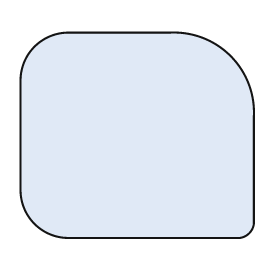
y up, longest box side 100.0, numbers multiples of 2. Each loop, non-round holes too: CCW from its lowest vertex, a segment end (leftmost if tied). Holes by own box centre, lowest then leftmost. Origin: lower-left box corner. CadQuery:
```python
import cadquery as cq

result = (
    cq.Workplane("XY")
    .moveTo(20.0, 0.0)
    .lineTo(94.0, 0.0)
    .threePointArc((98.0, 2.0), (100.0, 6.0))
    .lineTo(100.0, 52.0)
    .threePointArc((90.0, 78.0), (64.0, 88.0))
    .lineTo(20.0, 88.0)
    .threePointArc((6.0, 82.0), (0.0, 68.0))
    .lineTo(0.0, 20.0)
    .threePointArc((6.0, 6.0), (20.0, 0.0))
    .close()
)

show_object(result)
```